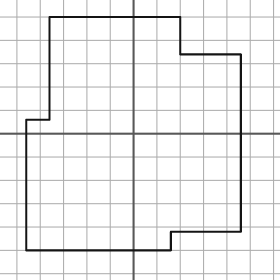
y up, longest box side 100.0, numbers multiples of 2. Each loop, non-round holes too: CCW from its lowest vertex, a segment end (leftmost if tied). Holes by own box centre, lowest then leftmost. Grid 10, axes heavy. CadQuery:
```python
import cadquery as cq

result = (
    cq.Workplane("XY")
    .moveTo(-46.0, -50.0)
    .lineTo(16.0, -50.0)
    .lineTo(16.0, -42.0)
    .lineTo(46.0, -42.0)
    .lineTo(46.0, 34.0)
    .lineTo(20.0, 34.0)
    .lineTo(20.0, 50.0)
    .lineTo(-36.0, 50.0)
    .lineTo(-36.0, 6.0)
    .lineTo(-46.0, 6.0)
    .close()
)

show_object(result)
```